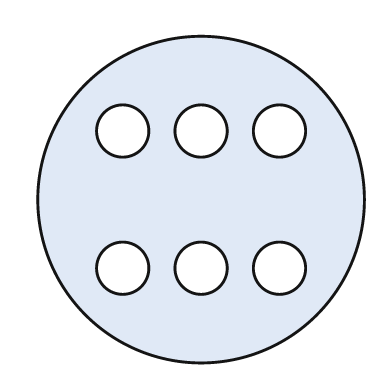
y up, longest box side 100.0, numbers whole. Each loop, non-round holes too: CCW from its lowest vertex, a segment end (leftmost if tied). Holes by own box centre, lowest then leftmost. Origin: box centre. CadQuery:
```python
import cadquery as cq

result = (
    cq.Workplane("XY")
    .moveTo(0.0, 0.0)
    .circle(50.0)
    .moveTo(-24.0, -21.0)
    .circle(8.0)
    .moveTo(0.0, -21.0)
    .circle(8.0)
    .moveTo(24.0, -21.0)
    .circle(8.0)
    .moveTo(-24.0, 21.0)
    .circle(8.0)
    .moveTo(0.0, 21.0)
    .circle(8.0)
    .moveTo(24.0, 21.0)
    .circle(8.0)
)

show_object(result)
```